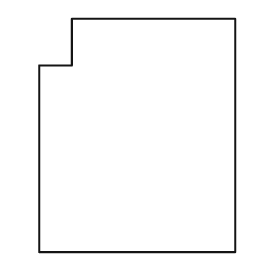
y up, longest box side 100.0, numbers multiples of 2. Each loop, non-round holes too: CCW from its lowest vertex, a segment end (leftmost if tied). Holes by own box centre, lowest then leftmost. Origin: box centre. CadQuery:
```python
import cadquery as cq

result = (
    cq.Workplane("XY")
    .moveTo(-42.0, -50.0)
    .lineTo(42.0, -50.0)
    .lineTo(42.0, 50.0)
    .lineTo(-28.0, 50.0)
    .lineTo(-28.0, 30.0)
    .lineTo(-42.0, 30.0)
    .close()
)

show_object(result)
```